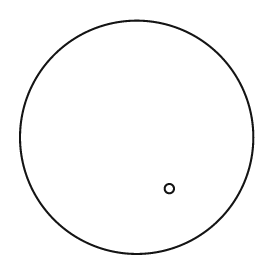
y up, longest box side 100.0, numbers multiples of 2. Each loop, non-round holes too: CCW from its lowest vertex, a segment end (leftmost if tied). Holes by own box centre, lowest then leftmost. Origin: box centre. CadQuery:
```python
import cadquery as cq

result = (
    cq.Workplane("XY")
    .moveTo(0.0, 0.0)
    .circle(50.0)
    .moveTo(14.0, -22.0)
    .circle(2.0)
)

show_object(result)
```